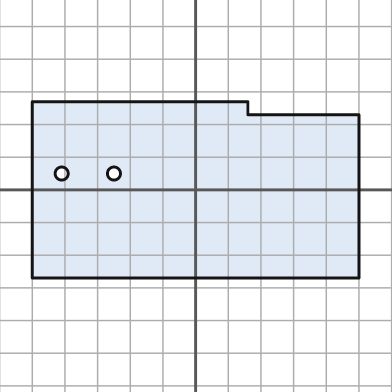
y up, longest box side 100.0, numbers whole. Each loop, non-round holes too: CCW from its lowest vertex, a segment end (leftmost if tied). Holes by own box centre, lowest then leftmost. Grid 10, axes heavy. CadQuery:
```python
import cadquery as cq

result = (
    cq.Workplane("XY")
    .moveTo(-50.0, -27.0)
    .lineTo(50.0, -27.0)
    .lineTo(50.0, 23.0)
    .lineTo(16.0, 23.0)
    .lineTo(16.0, 27.0)
    .lineTo(-50.0, 27.0)
    .close()
    .moveTo(-41.0, 5.0)
    .circle(2.0)
    .moveTo(-25.0, 5.0)
    .circle(2.0)
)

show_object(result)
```